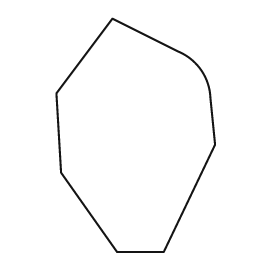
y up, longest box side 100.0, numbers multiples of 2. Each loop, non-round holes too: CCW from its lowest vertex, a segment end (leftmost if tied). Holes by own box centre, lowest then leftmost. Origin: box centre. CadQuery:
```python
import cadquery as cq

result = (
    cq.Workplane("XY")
    .moveTo(-8.0, -50.0)
    .lineTo(12.0, -50.0)
    .lineTo(34.0, -4.0)
    .lineTo(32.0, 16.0)
    .threePointArc((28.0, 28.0), (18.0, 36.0))
    .lineTo(-10.0, 50.0)
    .lineTo(-34.0, 18.0)
    .lineTo(-32.0, -16.0)
    .close()
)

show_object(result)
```